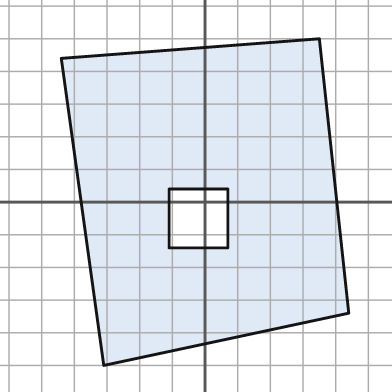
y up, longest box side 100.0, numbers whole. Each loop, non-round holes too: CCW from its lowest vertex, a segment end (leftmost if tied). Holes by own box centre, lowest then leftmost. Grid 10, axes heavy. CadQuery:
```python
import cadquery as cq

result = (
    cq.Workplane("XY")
    .moveTo(-31.0, -50.0)
    .lineTo(44.0, -34.0)
    .lineTo(35.0, 50.0)
    .lineTo(-44.0, 44.0)
    .close()
    .moveTo(-11.0, -14.0)
    .lineTo(7.0, -14.0)
    .lineTo(7.0, 4.0)
    .lineTo(-11.0, 4.0)
    .close()
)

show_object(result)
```